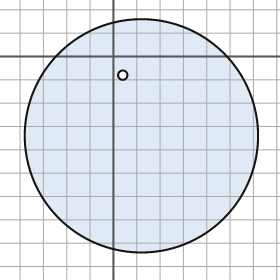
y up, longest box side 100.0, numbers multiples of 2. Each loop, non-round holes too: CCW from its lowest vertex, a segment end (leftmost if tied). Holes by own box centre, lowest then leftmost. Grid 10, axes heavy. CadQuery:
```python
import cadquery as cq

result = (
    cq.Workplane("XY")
    .moveTo(12.0, -34.0)
    .circle(50.0)
    .moveTo(4.0, -8.0)
    .circle(2.0)
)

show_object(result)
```